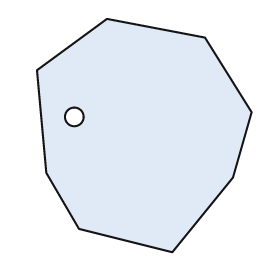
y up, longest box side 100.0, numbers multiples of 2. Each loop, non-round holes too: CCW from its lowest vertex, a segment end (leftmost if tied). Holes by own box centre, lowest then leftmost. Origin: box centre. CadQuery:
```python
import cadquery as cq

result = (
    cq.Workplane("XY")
    .moveTo(12.0, -50.0)
    .lineTo(38.0, -18.0)
    .lineTo(46.0, 10.0)
    .lineTo(26.0, 42.0)
    .lineTo(-16.0, 50.0)
    .lineTo(-46.0, 28.0)
    .lineTo(-42.0, -16.0)
    .lineTo(-28.0, -40.0)
    .close()
    .moveTo(-30.0, 8.0)
    .circle(4.0)
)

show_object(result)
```